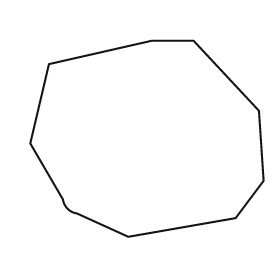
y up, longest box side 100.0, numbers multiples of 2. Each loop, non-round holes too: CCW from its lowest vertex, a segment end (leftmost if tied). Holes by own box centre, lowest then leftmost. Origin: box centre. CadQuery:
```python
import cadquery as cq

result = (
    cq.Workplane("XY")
    .moveTo(-8.0, -42.0)
    .lineTo(38.0, -34.0)
    .lineTo(50.0, -18.0)
    .lineTo(48.0, 12.0)
    .lineTo(20.0, 42.0)
    .lineTo(2.0, 42.0)
    .lineTo(-42.0, 32.0)
    .lineTo(-50.0, -2.0)
    .lineTo(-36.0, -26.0)
    .threePointArc((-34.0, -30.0), (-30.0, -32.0))
    .close()
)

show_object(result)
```